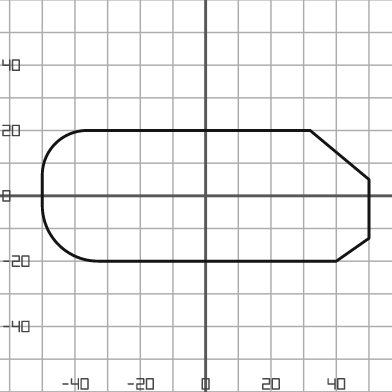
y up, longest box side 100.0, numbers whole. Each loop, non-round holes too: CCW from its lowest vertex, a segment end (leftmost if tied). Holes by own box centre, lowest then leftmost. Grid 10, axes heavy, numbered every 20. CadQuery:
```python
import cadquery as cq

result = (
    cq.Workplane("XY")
    .moveTo(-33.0, -20.0)
    .lineTo(40.0, -20.0)
    .lineTo(50.0, -13.0)
    .lineTo(50.0, 5.0)
    .lineTo(32.0, 20.0)
    .lineTo(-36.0, 20.0)
    .threePointArc((-46.0, 16.0), (-50.0, 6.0))
    .lineTo(-50.0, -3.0)
    .threePointArc((-45.0, -15.0), (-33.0, -20.0))
    .close()
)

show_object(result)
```